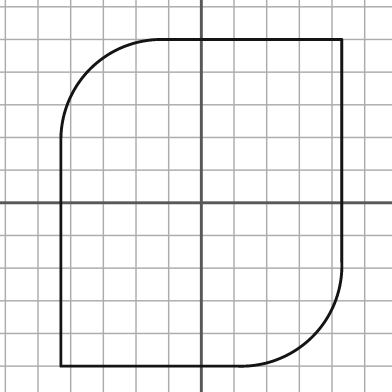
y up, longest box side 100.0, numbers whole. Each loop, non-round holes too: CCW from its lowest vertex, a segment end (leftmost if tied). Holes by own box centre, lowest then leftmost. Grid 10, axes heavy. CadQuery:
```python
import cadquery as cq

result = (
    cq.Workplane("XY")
    .moveTo(-43.0, -50.0)
    .lineTo(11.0, -50.0)
    .threePointArc((34.0, -41.0), (43.0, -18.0))
    .lineTo(43.0, 50.0)
    .lineTo(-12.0, 50.0)
    .threePointArc((-34.0, 41.0), (-43.0, 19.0))
    .close()
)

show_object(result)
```